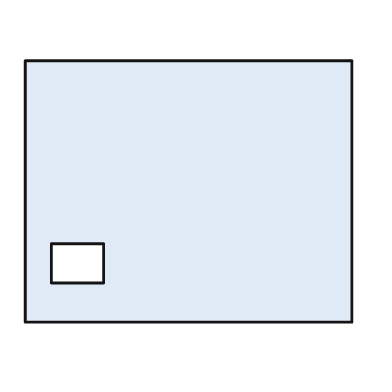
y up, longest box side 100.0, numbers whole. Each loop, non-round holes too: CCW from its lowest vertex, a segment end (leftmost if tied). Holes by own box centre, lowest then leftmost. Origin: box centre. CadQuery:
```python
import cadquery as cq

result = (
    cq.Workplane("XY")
    .moveTo(-50.0, -40.0)
    .lineTo(50.0, -40.0)
    .lineTo(50.0, 40.0)
    .lineTo(-50.0, 40.0)
    .close()
    .moveTo(-42.0, -28.0)
    .lineTo(-26.0, -28.0)
    .lineTo(-26.0, -16.0)
    .lineTo(-42.0, -16.0)
    .close()
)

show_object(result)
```